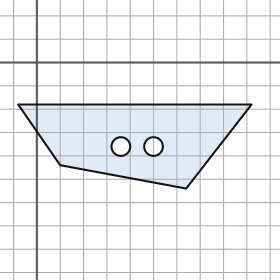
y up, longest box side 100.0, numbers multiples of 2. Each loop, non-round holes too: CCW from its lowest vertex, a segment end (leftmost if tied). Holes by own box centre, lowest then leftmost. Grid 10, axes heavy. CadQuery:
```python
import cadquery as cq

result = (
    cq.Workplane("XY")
    .moveTo(64.0, -54.0)
    .lineTo(92.0, -18.0)
    .lineTo(-8.0, -18.0)
    .lineTo(10.0, -44.0)
    .close()
    .moveTo(36.0, -36.0)
    .circle(4.0)
    .moveTo(50.0, -36.0)
    .circle(4.0)
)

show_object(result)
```